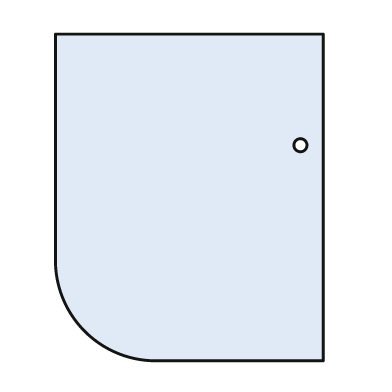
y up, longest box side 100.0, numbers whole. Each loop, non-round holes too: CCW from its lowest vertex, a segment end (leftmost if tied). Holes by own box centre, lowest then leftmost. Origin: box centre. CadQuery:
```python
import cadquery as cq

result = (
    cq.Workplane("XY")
    .moveTo(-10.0, -50.0)
    .lineTo(41.0, -50.0)
    .lineTo(41.0, 50.0)
    .lineTo(-41.0, 50.0)
    .lineTo(-41.0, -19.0)
    .threePointArc((-32.0, -41.0), (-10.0, -50.0))
    .close()
    .moveTo(34.0, 16.0)
    .circle(2.0)
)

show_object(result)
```